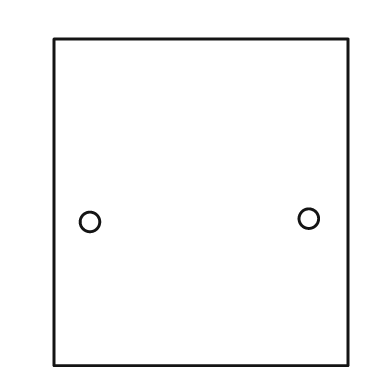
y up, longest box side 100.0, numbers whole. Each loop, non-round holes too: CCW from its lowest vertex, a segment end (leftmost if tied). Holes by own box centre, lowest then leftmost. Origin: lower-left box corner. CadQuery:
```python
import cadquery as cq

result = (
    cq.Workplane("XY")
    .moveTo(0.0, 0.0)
    .lineTo(90.0, 0.0)
    .lineTo(90.0, 100.0)
    .lineTo(0.0, 100.0)
    .close()
    .moveTo(11.0, 44.0)
    .circle(3.0)
    .moveTo(78.0, 45.0)
    .circle(3.0)
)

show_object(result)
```